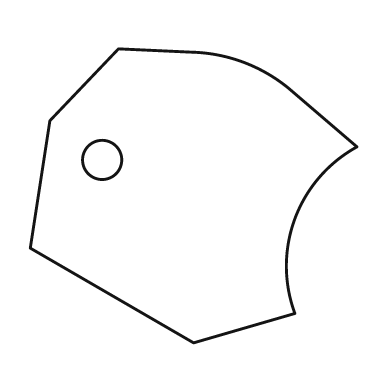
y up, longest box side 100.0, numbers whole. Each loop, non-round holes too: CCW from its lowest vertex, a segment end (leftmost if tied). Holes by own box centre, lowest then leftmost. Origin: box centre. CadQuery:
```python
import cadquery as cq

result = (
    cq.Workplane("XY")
    .moveTo(0.0, -45.0)
    .lineTo(31.0, -36.0)
    .threePointArc((31.0, -7.0), (50.0, 15.0))
    .lineTo(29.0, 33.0)
    .threePointArc((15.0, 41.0), (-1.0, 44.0))
    .lineTo(-23.0, 45.0)
    .lineTo(-44.0, 23.0)
    .lineTo(-50.0, -16.0)
    .close()
    .moveTo(-28.0, 11.0)
    .circle(6.0)
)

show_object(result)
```